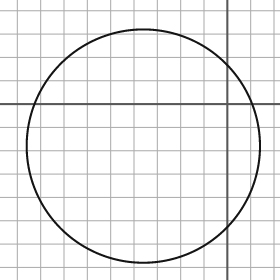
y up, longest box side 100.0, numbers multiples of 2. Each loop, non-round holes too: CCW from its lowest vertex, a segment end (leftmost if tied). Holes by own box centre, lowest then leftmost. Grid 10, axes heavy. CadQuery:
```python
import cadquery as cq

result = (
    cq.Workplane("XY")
    .moveTo(-36.0, -18.0)
    .circle(50.0)
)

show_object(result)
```